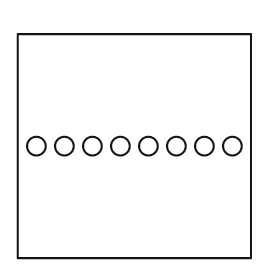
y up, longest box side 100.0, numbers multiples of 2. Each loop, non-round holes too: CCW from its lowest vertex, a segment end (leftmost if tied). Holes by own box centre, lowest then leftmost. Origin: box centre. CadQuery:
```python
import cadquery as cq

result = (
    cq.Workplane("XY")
    .moveTo(-50.0, -48.0)
    .lineTo(50.0, -48.0)
    .lineTo(50.0, 48.0)
    .lineTo(-50.0, 48.0)
    .close()
    .moveTo(-42.0, 0.0)
    .circle(4.0)
    .moveTo(-30.0, 0.0)
    .circle(4.0)
    .moveTo(-18.0, 0.0)
    .circle(4.0)
    .moveTo(-6.0, 0.0)
    .circle(4.0)
    .moveTo(6.0, 0.0)
    .circle(4.0)
    .moveTo(18.0, 0.0)
    .circle(4.0)
    .moveTo(30.0, 0.0)
    .circle(4.0)
    .moveTo(42.0, 0.0)
    .circle(4.0)
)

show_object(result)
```